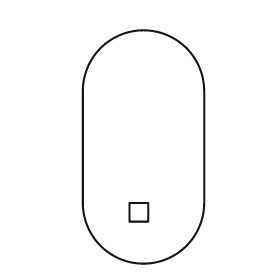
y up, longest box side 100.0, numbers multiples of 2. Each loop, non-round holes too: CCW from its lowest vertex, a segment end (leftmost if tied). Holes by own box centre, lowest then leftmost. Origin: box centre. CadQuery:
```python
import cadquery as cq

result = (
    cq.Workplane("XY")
    .moveTo(-26.0, -24.0)
    .threePointArc((0.0, -50.0), (26.0, -24.0))
    .lineTo(26.0, 24.0)
    .threePointArc((0.0, 50.0), (-26.0, 24.0))
    .close()
    .moveTo(-6.0, -32.0)
    .lineTo(2.0, -32.0)
    .lineTo(2.0, -24.0)
    .lineTo(-6.0, -24.0)
    .close()
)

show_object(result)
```